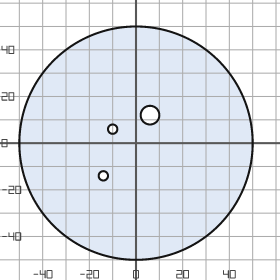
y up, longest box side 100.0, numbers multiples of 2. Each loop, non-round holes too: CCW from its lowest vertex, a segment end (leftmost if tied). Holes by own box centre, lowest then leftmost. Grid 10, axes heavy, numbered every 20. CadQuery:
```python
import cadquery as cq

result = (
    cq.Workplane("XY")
    .moveTo(0.0, 0.0)
    .circle(50.0)
    .moveTo(-14.0, -14.0)
    .circle(2.0)
    .moveTo(-10.0, 6.0)
    .circle(2.0)
    .moveTo(6.0, 12.0)
    .circle(4.0)
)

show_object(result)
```